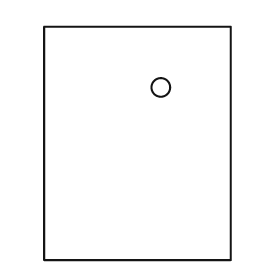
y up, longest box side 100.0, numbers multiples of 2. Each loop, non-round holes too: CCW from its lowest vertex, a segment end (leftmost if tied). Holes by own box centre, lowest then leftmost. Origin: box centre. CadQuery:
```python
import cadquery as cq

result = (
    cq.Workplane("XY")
    .moveTo(-40.0, -50.0)
    .lineTo(40.0, -50.0)
    .lineTo(40.0, 50.0)
    .lineTo(-40.0, 50.0)
    .close()
    .moveTo(10.0, 24.0)
    .circle(4.0)
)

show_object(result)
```